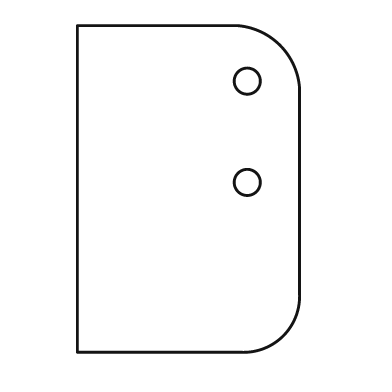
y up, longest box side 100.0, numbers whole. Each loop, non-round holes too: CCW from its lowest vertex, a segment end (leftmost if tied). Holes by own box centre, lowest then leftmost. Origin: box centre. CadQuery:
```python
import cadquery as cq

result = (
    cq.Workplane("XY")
    .moveTo(-34.0, -50.0)
    .lineTo(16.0, -50.0)
    .threePointArc((29.0, -45.0), (34.0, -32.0))
    .lineTo(34.0, 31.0)
    .threePointArc((28.0, 44.0), (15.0, 50.0))
    .lineTo(-34.0, 50.0)
    .close()
    .moveTo(18.0, 2.0)
    .circle(4.0)
    .moveTo(18.0, 33.0)
    .circle(4.0)
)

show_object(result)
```